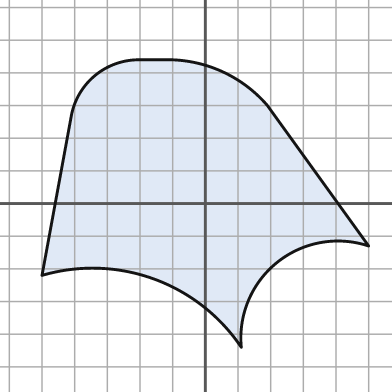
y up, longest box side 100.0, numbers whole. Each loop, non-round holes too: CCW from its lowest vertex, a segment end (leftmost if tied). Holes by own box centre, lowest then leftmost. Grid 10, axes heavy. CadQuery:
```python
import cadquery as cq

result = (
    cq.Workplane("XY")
    .moveTo(11.0, -44.0)
    .threePointArc((22.0, -18.0), (50.0, -13.0))
    .lineTo(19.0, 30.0)
    .threePointArc((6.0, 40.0), (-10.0, 44.0))
    .lineTo(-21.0, 44.0)
    .threePointArc((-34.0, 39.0), (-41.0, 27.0))
    .lineTo(-50.0, -22.0)
    .threePointArc((-16.0, -23.0), (11.0, -44.0))
    .close()
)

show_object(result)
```